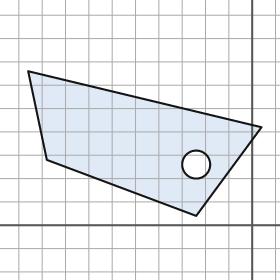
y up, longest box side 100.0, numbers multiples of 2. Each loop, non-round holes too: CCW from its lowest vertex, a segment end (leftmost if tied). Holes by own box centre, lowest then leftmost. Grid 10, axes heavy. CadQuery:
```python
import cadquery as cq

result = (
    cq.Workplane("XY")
    .moveTo(-24.0, 4.0)
    .lineTo(4.0, 42.0)
    .lineTo(-96.0, 66.0)
    .lineTo(-88.0, 28.0)
    .close()
    .moveTo(-24.0, 26.0)
    .circle(6.0)
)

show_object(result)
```